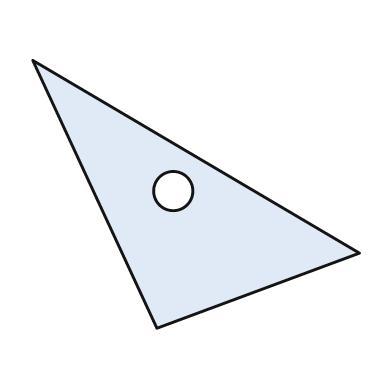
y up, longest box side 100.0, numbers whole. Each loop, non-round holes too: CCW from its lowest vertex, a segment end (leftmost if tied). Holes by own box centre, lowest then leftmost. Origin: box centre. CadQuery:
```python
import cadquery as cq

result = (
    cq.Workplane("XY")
    .moveTo(-12.0, -41.0)
    .lineTo(50.0, -18.0)
    .lineTo(-50.0, 41.0)
    .close()
    .moveTo(-7.0, 1.0)
    .circle(6.0)
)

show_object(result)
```